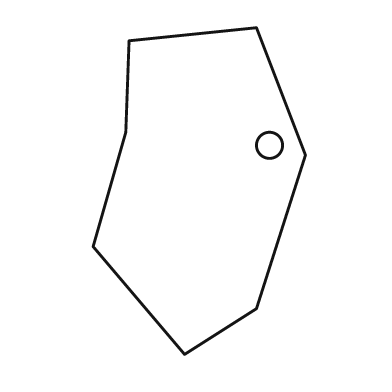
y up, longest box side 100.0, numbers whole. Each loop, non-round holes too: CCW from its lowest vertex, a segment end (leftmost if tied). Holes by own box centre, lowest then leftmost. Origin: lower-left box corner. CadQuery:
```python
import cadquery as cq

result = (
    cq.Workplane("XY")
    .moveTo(28.0, 0.0)
    .lineTo(50.0, 14.0)
    .lineTo(65.0, 61.0)
    .lineTo(50.0, 100.0)
    .lineTo(11.0, 96.0)
    .lineTo(10.0, 68.0)
    .lineTo(0.0, 33.0)
    .close()
    .moveTo(54.0, 64.0)
    .circle(4.0)
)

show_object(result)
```